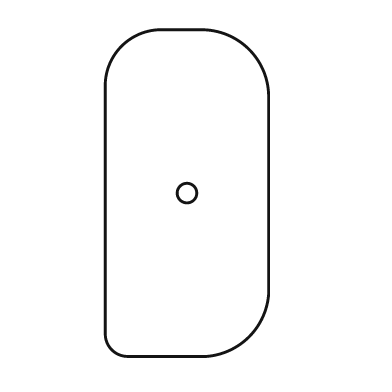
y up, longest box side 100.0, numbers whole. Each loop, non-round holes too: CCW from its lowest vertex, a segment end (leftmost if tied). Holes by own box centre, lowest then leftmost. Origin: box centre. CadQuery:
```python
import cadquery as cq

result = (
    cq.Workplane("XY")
    .moveTo(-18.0, -50.0)
    .lineTo(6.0, -50.0)
    .threePointArc((19.0, -44.0), (25.0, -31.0))
    .lineTo(25.0, 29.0)
    .threePointArc((19.0, 44.0), (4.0, 50.0))
    .lineTo(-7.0, 50.0)
    .threePointArc((-20.0, 45.0), (-25.0, 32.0))
    .lineTo(-25.0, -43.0)
    .threePointArc((-23.0, -48.0), (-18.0, -50.0))
    .close()
    .moveTo(0.0, 0.0)
    .circle(3.0)
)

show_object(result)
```